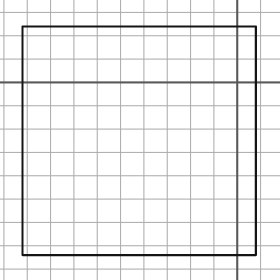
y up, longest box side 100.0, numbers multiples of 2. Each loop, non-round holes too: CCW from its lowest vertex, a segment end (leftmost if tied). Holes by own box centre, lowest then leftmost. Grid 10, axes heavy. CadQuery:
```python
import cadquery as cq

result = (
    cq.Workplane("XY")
    .moveTo(-92.0, -74.0)
    .lineTo(8.0, -74.0)
    .lineTo(8.0, 24.0)
    .lineTo(-92.0, 24.0)
    .close()
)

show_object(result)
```